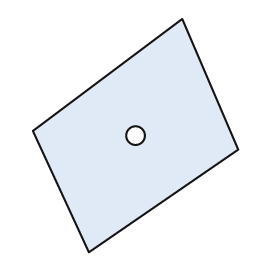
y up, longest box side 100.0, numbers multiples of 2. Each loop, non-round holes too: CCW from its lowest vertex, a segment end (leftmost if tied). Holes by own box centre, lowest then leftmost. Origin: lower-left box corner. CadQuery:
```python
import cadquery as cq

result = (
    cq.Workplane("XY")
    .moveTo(24.0, 0.0)
    .lineTo(88.0, 44.0)
    .lineTo(64.0, 100.0)
    .lineTo(0.0, 52.0)
    .close()
    .moveTo(44.0, 50.0)
    .circle(4.0)
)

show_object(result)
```